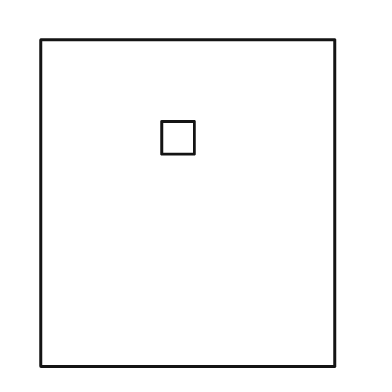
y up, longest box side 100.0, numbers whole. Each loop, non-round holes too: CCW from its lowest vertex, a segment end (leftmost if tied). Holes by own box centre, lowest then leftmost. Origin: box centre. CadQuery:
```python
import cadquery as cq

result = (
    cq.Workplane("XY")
    .moveTo(-45.0, -50.0)
    .lineTo(45.0, -50.0)
    .lineTo(45.0, 50.0)
    .lineTo(-45.0, 50.0)
    .close()
    .moveTo(-8.0, 15.0)
    .lineTo(2.0, 15.0)
    .lineTo(2.0, 25.0)
    .lineTo(-8.0, 25.0)
    .close()
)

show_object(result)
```